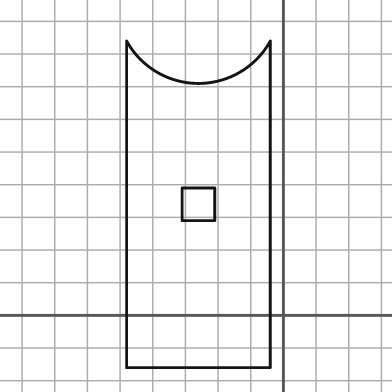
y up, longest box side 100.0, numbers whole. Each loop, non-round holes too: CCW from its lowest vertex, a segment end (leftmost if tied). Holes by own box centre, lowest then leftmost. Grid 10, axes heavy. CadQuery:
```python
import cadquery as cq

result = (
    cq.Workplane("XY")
    .moveTo(-48.0, -16.0)
    .lineTo(-4.0, -16.0)
    .lineTo(-4.0, 84.0)
    .threePointArc((-26.0, 71.0), (-48.0, 84.0))
    .close()
    .moveTo(-31.0, 29.0)
    .lineTo(-21.0, 29.0)
    .lineTo(-21.0, 39.0)
    .lineTo(-31.0, 39.0)
    .close()
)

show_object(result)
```